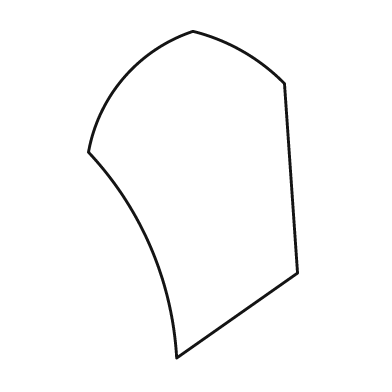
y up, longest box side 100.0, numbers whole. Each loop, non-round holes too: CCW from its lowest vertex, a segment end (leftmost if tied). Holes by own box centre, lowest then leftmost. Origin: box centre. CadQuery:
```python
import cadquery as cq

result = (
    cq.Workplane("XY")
    .moveTo(-5.0, -50.0)
    .lineTo(32.0, -24.0)
    .lineTo(28.0, 34.0)
    .threePointArc((15.0, 44.0), (0.0, 50.0))
    .threePointArc((-21.0, 36.0), (-32.0, 13.0))
    .threePointArc((-13.0, -16.0), (-5.0, -50.0))
    .close()
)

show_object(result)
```